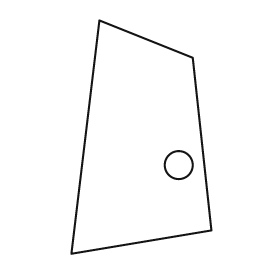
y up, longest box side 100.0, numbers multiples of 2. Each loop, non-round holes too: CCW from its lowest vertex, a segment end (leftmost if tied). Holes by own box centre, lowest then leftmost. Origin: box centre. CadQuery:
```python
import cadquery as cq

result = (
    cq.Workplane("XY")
    .moveTo(-30.0, -50.0)
    .lineTo(30.0, -40.0)
    .lineTo(22.0, 34.0)
    .lineTo(-18.0, 50.0)
    .close()
    .moveTo(16.0, -12.0)
    .circle(6.0)
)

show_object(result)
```